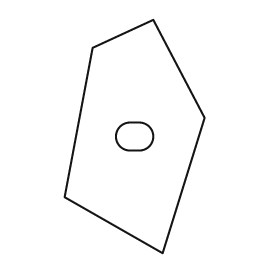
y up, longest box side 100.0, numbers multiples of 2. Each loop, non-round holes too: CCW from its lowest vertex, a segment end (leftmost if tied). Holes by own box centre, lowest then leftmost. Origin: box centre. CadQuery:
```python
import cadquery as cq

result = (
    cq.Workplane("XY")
    .moveTo(12.0, -50.0)
    .lineTo(30.0, 8.0)
    .lineTo(8.0, 50.0)
    .lineTo(-18.0, 38.0)
    .lineTo(-30.0, -26.0)
    .close()
    .moveTo(-2.0, -6.0)
    .lineTo(2.0, -6.0)
    .threePointArc((8.0, 0.0), (2.0, 6.0))
    .lineTo(-2.0, 6.0)
    .threePointArc((-8.0, 0.0), (-2.0, -6.0))
    .close()
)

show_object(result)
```